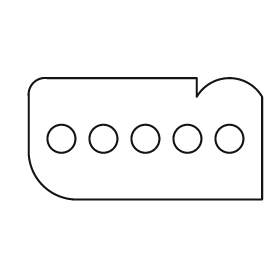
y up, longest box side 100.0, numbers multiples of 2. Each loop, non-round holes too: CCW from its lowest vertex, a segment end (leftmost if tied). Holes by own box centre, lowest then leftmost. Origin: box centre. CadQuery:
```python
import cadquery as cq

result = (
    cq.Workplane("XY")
    .moveTo(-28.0, -26.0)
    .lineTo(50.0, -26.0)
    .lineTo(50.0, 18.0)
    .threePointArc((36.0, 26.0), (22.0, 18.0))
    .lineTo(22.0, 26.0)
    .lineTo(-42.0, 26.0)
    .threePointArc((-48.0, 24.0), (-50.0, 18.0))
    .lineTo(-50.0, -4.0)
    .threePointArc((-44.0, -20.0), (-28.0, -26.0))
    .close()
    .moveTo(-36.0, 0.0)
    .circle(6.0)
    .moveTo(-18.0, 0.0)
    .circle(6.0)
    .moveTo(0.0, 0.0)
    .circle(6.0)
    .moveTo(18.0, 0.0)
    .circle(6.0)
    .moveTo(36.0, 0.0)
    .circle(6.0)
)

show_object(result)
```